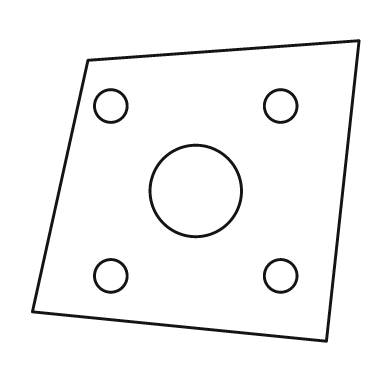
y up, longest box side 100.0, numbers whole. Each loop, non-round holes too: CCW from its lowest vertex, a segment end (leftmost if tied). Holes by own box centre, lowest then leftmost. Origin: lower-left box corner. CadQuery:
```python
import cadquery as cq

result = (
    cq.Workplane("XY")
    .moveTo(90.0, 0.0)
    .lineTo(100.0, 92.0)
    .lineTo(17.0, 86.0)
    .lineTo(0.0, 9.0)
    .close()
    .moveTo(24.0, 20.0)
    .circle(5.0)
    .moveTo(76.0, 20.0)
    .circle(5.0)
    .moveTo(50.0, 46.0)
    .circle(14.0)
    .moveTo(24.0, 72.0)
    .circle(5.0)
    .moveTo(76.0, 72.0)
    .circle(5.0)
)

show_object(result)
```